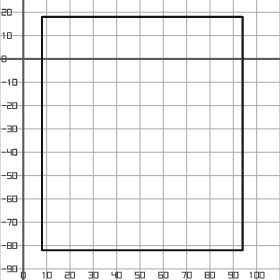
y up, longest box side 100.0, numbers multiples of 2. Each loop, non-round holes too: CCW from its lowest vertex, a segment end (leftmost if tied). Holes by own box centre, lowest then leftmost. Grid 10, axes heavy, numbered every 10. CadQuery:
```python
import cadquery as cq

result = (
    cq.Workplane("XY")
    .moveTo(8.0, -82.0)
    .lineTo(94.0, -82.0)
    .lineTo(94.0, 18.0)
    .lineTo(8.0, 18.0)
    .close()
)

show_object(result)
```